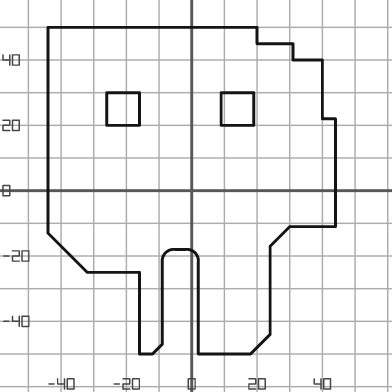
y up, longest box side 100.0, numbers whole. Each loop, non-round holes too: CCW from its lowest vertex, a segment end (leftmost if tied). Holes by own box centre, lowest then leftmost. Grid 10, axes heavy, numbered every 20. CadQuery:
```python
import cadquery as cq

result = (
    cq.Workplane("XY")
    .moveTo(-16.0, -50.0)
    .lineTo(-12.0, -50.0)
    .lineTo(-9.0, -47.0)
    .lineTo(-9.0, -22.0)
    .threePointArc((-8.0, -19.0), (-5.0, -18.0))
    .lineTo(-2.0, -18.0)
    .threePointArc((1.0, -19.0), (2.0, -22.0))
    .lineTo(2.0, -50.0)
    .lineTo(18.0, -50.0)
    .lineTo(24.0, -44.0)
    .lineTo(24.0, -17.0)
    .lineTo(30.0, -11.0)
    .lineTo(44.0, -11.0)
    .lineTo(44.0, 22.0)
    .lineTo(40.0, 22.0)
    .lineTo(40.0, 40.0)
    .lineTo(31.0, 40.0)
    .lineTo(31.0, 45.0)
    .lineTo(20.0, 45.0)
    .lineTo(20.0, 50.0)
    .lineTo(-44.0, 50.0)
    .lineTo(-44.0, -13.0)
    .lineTo(-32.0, -25.0)
    .lineTo(-16.0, -25.0)
    .close()
    .moveTo(-26.0, 20.0)
    .lineTo(-16.0, 20.0)
    .lineTo(-16.0, 30.0)
    .lineTo(-26.0, 30.0)
    .close()
    .moveTo(9.0, 20.0)
    .lineTo(19.0, 20.0)
    .lineTo(19.0, 30.0)
    .lineTo(9.0, 30.0)
    .close()
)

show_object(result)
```